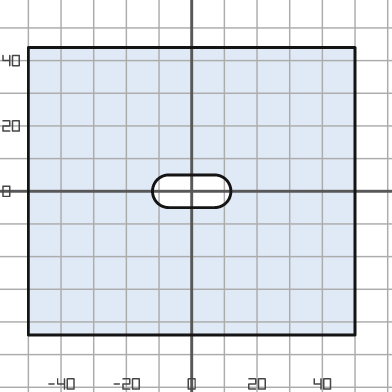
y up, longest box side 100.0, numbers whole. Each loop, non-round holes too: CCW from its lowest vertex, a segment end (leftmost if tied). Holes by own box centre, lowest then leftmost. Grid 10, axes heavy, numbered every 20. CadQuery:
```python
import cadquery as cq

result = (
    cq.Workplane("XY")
    .moveTo(-50.0, -44.0)
    .lineTo(50.0, -44.0)
    .lineTo(50.0, 44.0)
    .lineTo(-50.0, 44.0)
    .close()
    .moveTo(-7.0, -5.0)
    .lineTo(7.0, -5.0)
    .threePointArc((12.0, 0.0), (7.0, 5.0))
    .lineTo(-7.0, 5.0)
    .threePointArc((-12.0, 0.0), (-7.0, -5.0))
    .close()
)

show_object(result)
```